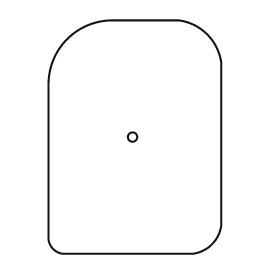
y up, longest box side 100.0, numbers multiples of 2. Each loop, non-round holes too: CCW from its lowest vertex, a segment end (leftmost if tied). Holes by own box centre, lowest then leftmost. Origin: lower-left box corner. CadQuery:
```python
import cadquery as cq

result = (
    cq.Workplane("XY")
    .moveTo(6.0, 0.0)
    .lineTo(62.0, 0.0)
    .threePointArc((70.0, 4.0), (74.0, 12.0))
    .lineTo(74.0, 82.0)
    .threePointArc((68.0, 94.0), (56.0, 100.0))
    .lineTo(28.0, 100.0)
    .threePointArc((8.0, 92.0), (0.0, 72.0))
    .lineTo(0.0, 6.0)
    .threePointArc((2.0, 2.0), (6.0, 0.0))
    .close()
    .moveTo(36.0, 50.0)
    .circle(2.0)
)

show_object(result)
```